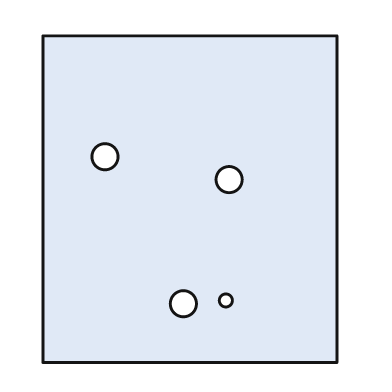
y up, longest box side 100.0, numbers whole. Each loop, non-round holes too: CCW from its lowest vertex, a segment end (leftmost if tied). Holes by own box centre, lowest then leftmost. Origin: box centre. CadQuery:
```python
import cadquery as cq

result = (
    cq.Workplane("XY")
    .moveTo(-45.0, -50.0)
    .lineTo(45.0, -50.0)
    .lineTo(45.0, 50.0)
    .lineTo(-45.0, 50.0)
    .close()
    .moveTo(-2.0, -32.0)
    .circle(4.0)
    .moveTo(11.0, -31.0)
    .circle(2.0)
    .moveTo(12.0, 6.0)
    .circle(4.0)
    .moveTo(-26.0, 13.0)
    .circle(4.0)
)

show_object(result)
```